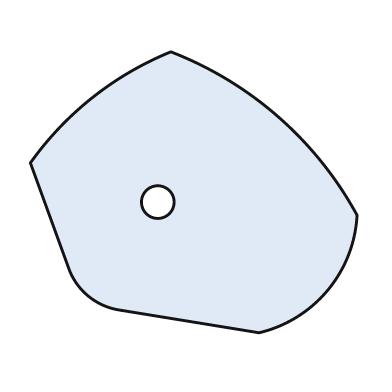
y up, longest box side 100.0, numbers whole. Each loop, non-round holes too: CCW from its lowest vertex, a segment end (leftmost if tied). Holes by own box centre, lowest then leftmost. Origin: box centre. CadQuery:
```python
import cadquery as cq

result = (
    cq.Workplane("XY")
    .moveTo(20.0, -43.0)
    .threePointArc((41.0, -30.0), (50.0, -7.0))
    .threePointArc((26.0, 23.0), (-7.0, 43.0))
    .threePointArc((-31.0, 29.0), (-50.0, 9.0))
    .lineTo(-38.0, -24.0)
    .threePointArc((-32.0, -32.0), (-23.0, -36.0))
    .close()
    .moveTo(-11.0, -3.0)
    .circle(5.0)
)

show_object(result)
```